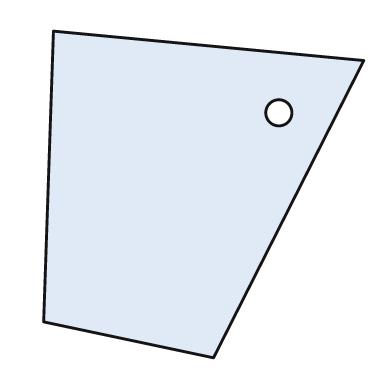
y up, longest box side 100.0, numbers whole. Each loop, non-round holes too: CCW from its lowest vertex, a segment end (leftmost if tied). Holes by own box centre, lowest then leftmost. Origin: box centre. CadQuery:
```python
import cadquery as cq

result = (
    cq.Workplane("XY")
    .moveTo(3.0, -50.0)
    .lineTo(49.0, 41.0)
    .lineTo(-46.0, 50.0)
    .lineTo(-49.0, -39.0)
    .close()
    .moveTo(23.0, 25.0)
    .circle(4.0)
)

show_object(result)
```